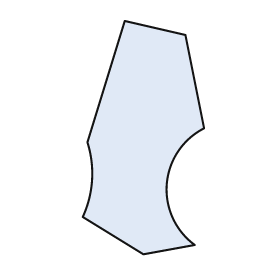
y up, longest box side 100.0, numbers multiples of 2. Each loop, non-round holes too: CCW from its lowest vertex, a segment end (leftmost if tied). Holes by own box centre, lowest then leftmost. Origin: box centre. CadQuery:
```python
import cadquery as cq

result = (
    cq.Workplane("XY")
    .moveTo(0.0, -50.0)
    .lineTo(22.0, -46.0)
    .threePointArc((10.0, -20.0), (26.0, 4.0))
    .lineTo(18.0, 44.0)
    .lineTo(-8.0, 50.0)
    .lineTo(-24.0, -2.0)
    .threePointArc((-22.0, -18.0), (-26.0, -34.0))
    .close()
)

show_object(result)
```